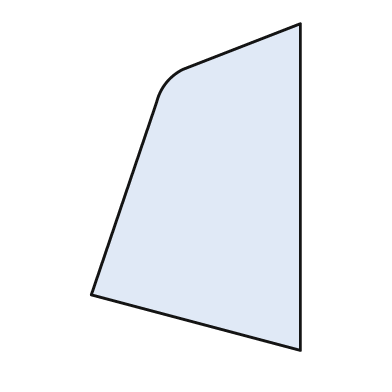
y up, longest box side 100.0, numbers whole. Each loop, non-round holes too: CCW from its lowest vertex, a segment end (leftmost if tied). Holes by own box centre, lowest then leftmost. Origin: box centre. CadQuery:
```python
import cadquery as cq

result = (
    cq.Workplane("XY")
    .moveTo(32.0, -50.0)
    .lineTo(32.0, 50.0)
    .lineTo(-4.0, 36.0)
    .threePointArc((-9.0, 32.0), (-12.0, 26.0))
    .lineTo(-32.0, -33.0)
    .close()
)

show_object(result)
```